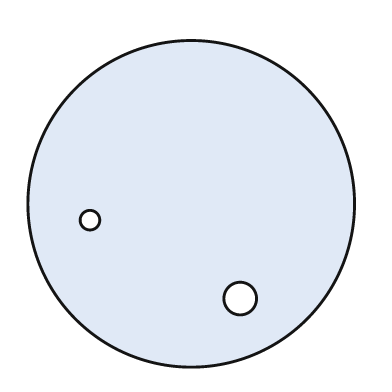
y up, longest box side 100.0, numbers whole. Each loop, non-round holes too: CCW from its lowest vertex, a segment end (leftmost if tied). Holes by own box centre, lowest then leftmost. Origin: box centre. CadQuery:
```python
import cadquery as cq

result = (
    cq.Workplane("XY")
    .moveTo(0.0, 0.0)
    .circle(50.0)
    .moveTo(15.0, -29.0)
    .circle(5.0)
    .moveTo(-31.0, -5.0)
    .circle(3.0)
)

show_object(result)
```